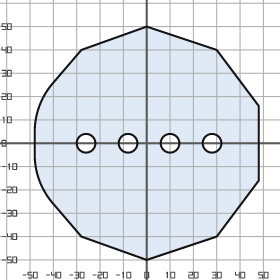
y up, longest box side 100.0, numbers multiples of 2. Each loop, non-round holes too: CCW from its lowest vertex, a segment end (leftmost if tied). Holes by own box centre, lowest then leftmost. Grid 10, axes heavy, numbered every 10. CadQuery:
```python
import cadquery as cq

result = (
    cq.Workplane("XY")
    .moveTo(0.0, -50.0)
    .lineTo(30.0, -40.0)
    .lineTo(48.0, -16.0)
    .lineTo(48.0, 16.0)
    .lineTo(30.0, 40.0)
    .lineTo(0.0, 50.0)
    .lineTo(-28.0, 40.0)
    .lineTo(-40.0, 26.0)
    .threePointArc((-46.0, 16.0), (-48.0, 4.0))
    .lineTo(-48.0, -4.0)
    .threePointArc((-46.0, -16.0), (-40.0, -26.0))
    .lineTo(-28.0, -40.0)
    .close()
    .moveTo(-26.0, 0.0)
    .circle(4.0)
    .moveTo(-8.0, 0.0)
    .circle(4.0)
    .moveTo(10.0, 0.0)
    .circle(4.0)
    .moveTo(28.0, 0.0)
    .circle(4.0)
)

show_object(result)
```